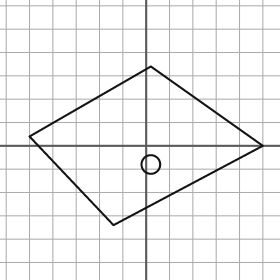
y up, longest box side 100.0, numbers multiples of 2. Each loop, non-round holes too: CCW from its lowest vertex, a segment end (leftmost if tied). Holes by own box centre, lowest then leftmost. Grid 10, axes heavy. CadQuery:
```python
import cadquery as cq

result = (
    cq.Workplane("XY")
    .moveTo(-14.0, -34.0)
    .lineTo(50.0, 0.0)
    .lineTo(2.0, 34.0)
    .lineTo(-50.0, 4.0)
    .close()
    .moveTo(2.0, -8.0)
    .circle(4.0)
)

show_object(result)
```